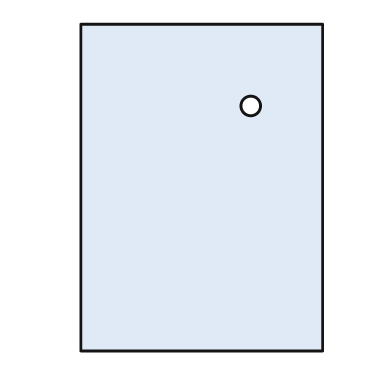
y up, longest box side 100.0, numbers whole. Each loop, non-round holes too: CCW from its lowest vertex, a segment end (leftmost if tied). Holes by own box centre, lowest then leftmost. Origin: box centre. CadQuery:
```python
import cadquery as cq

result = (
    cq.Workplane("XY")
    .moveTo(-37.0, -50.0)
    .lineTo(37.0, -50.0)
    .lineTo(37.0, 50.0)
    .lineTo(-37.0, 50.0)
    .close()
    .moveTo(15.0, 25.0)
    .circle(3.0)
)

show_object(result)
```